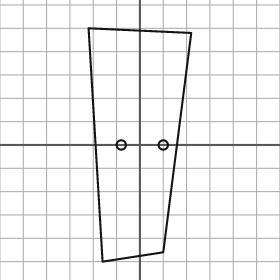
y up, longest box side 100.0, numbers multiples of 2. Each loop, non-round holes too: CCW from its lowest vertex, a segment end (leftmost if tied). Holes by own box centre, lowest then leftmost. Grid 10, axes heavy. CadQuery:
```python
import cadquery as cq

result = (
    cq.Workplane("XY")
    .moveTo(-16.0, -50.0)
    .lineTo(10.0, -46.0)
    .lineTo(22.0, 48.0)
    .lineTo(-22.0, 50.0)
    .close()
    .moveTo(-8.0, 0.0)
    .circle(2.0)
    .moveTo(10.0, 0.0)
    .circle(2.0)
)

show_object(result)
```